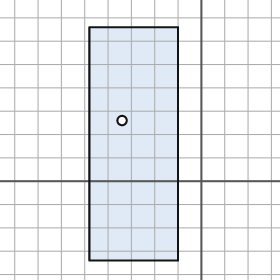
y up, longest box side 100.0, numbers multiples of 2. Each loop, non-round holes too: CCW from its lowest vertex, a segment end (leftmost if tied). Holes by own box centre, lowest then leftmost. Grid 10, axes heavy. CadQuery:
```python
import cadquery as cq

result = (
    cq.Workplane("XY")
    .moveTo(-48.0, -34.0)
    .lineTo(-10.0, -34.0)
    .lineTo(-10.0, 66.0)
    .lineTo(-48.0, 66.0)
    .close()
    .moveTo(-34.0, 26.0)
    .circle(2.0)
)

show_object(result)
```